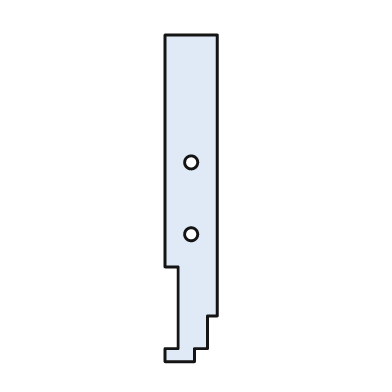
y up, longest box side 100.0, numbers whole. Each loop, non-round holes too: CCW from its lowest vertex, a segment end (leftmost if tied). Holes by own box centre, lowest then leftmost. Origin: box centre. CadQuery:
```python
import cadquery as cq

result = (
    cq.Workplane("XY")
    .moveTo(-8.0, -50.0)
    .lineTo(1.0, -50.0)
    .lineTo(1.0, -46.0)
    .lineTo(5.0, -46.0)
    .lineTo(5.0, -36.0)
    .lineTo(8.0, -36.0)
    .lineTo(8.0, 50.0)
    .lineTo(-8.0, 50.0)
    .lineTo(-8.0, -21.0)
    .lineTo(-4.0, -21.0)
    .lineTo(-4.0, -46.0)
    .lineTo(-8.0, -46.0)
    .close()
    .moveTo(0.0, -11.0)
    .circle(2.0)
    .moveTo(0.0, 11.0)
    .circle(2.0)
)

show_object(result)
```